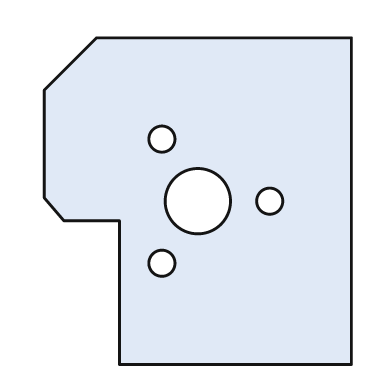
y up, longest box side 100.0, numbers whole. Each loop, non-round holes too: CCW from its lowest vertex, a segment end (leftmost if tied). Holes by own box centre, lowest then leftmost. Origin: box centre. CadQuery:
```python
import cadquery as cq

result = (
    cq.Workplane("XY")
    .moveTo(-24.0, -50.0)
    .lineTo(47.0, -50.0)
    .lineTo(47.0, 50.0)
    .lineTo(-31.0, 50.0)
    .lineTo(-47.0, 34.0)
    .lineTo(-47.0, 1.0)
    .lineTo(-41.0, -6.0)
    .lineTo(-24.0, -6.0)
    .close()
    .moveTo(-11.0, -19.0)
    .circle(4.0)
    .moveTo(0.0, 0.0)
    .circle(10.0)
    .moveTo(22.0, 0.0)
    .circle(4.0)
    .moveTo(-11.0, 19.0)
    .circle(4.0)
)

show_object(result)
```